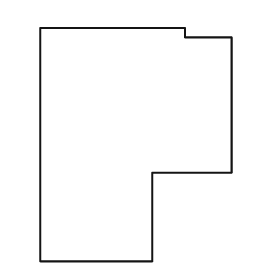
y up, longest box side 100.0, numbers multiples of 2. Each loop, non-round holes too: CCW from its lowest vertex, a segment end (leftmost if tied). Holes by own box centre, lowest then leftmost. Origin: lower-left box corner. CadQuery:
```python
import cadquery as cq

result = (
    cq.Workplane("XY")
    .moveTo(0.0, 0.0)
    .lineTo(48.0, 0.0)
    .lineTo(48.0, 38.0)
    .lineTo(82.0, 38.0)
    .lineTo(82.0, 96.0)
    .lineTo(62.0, 96.0)
    .lineTo(62.0, 100.0)
    .lineTo(0.0, 100.0)
    .close()
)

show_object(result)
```